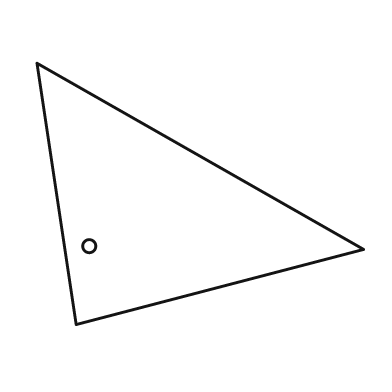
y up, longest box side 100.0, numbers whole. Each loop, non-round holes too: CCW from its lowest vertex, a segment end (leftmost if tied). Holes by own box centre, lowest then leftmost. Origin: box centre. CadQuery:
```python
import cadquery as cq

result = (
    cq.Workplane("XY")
    .moveTo(-38.0, -40.0)
    .lineTo(50.0, -17.0)
    .lineTo(-50.0, 40.0)
    .close()
    .moveTo(-34.0, -16.0)
    .circle(2.0)
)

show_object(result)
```